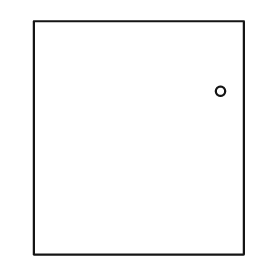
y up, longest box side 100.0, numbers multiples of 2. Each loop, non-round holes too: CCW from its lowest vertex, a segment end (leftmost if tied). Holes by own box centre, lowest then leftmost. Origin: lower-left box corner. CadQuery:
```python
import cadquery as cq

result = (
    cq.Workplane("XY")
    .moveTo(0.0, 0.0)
    .lineTo(90.0, 0.0)
    .lineTo(90.0, 100.0)
    .lineTo(0.0, 100.0)
    .close()
    .moveTo(80.0, 70.0)
    .circle(2.0)
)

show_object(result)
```